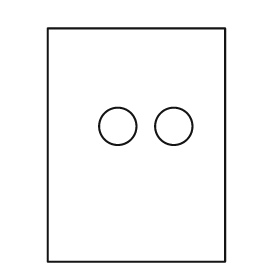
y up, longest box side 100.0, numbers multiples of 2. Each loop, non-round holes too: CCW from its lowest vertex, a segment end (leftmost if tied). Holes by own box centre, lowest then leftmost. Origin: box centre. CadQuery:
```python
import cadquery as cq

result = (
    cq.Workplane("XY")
    .moveTo(-38.0, -50.0)
    .lineTo(38.0, -50.0)
    .lineTo(38.0, 50.0)
    .lineTo(-38.0, 50.0)
    .close()
    .moveTo(-8.0, 8.0)
    .circle(8.0)
    .moveTo(16.0, 8.0)
    .circle(8.0)
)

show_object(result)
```